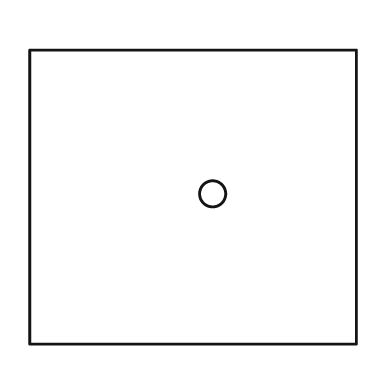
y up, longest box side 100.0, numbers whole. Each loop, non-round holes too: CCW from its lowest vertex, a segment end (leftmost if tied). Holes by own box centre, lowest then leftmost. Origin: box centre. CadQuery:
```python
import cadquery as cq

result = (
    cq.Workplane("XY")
    .moveTo(-50.0, -45.0)
    .lineTo(50.0, -45.0)
    .lineTo(50.0, 45.0)
    .lineTo(-50.0, 45.0)
    .close()
    .moveTo(6.0, 1.0)
    .circle(4.0)
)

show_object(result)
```